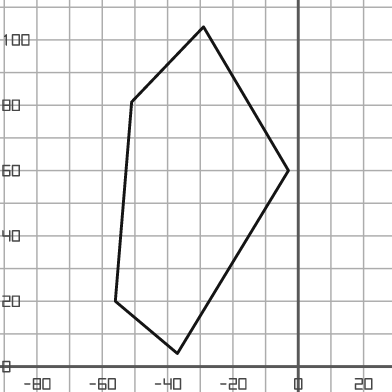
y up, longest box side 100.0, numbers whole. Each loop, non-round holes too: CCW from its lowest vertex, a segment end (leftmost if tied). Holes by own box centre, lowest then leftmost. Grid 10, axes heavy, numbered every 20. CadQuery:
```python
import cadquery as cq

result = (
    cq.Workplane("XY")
    .moveTo(-37.0, 4.0)
    .lineTo(-3.0, 60.0)
    .lineTo(-29.0, 104.0)
    .lineTo(-51.0, 81.0)
    .lineTo(-56.0, 20.0)
    .close()
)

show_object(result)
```